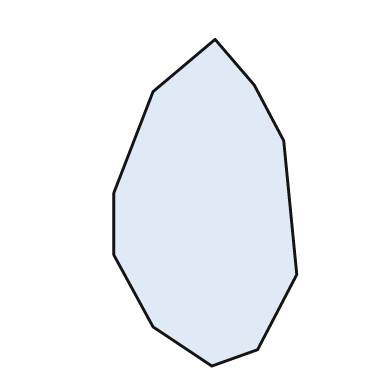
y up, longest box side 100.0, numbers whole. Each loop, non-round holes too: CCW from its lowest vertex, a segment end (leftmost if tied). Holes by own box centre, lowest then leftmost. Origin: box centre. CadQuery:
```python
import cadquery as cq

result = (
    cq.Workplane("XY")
    .moveTo(2.0, -50.0)
    .lineTo(16.0, -45.0)
    .lineTo(28.0, -22.0)
    .lineTo(24.0, 19.0)
    .lineTo(15.0, 36.0)
    .lineTo(3.0, 50.0)
    .lineTo(-16.0, 34.0)
    .lineTo(-28.0, 3.0)
    .lineTo(-28.0, -16.0)
    .lineTo(-16.0, -38.0)
    .close()
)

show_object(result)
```